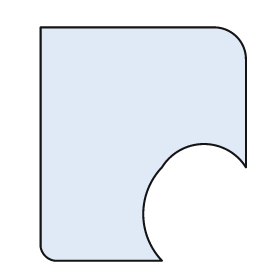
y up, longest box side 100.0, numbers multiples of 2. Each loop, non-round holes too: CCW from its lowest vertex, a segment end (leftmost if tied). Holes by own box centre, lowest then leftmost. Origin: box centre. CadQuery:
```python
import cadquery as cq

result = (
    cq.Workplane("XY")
    .moveTo(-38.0, -50.0)
    .lineTo(8.0, -50.0)
    .threePointArc((0.0, -30.0), (8.0, -10.0))
    .threePointArc((26.0, 0.0), (44.0, -10.0))
    .lineTo(44.0, 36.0)
    .threePointArc((40.0, 46.0), (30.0, 50.0))
    .lineTo(-44.0, 50.0)
    .lineTo(-44.0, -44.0)
    .threePointArc((-42.0, -48.0), (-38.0, -50.0))
    .close()
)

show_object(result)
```